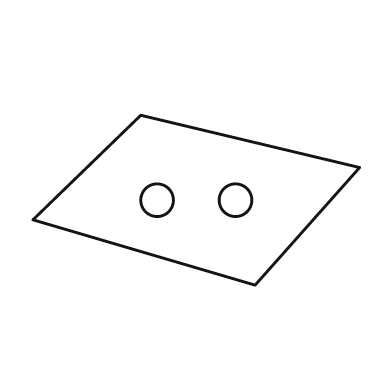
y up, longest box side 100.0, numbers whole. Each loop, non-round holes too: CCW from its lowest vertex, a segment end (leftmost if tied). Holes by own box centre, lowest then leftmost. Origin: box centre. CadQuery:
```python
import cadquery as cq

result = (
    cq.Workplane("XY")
    .moveTo(18.0, -26.0)
    .lineTo(50.0, 10.0)
    .lineTo(-17.0, 26.0)
    .lineTo(-50.0, -6.0)
    .close()
    .moveTo(-12.0, 0.0)
    .circle(5.0)
    .moveTo(12.0, 0.0)
    .circle(5.0)
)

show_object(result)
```